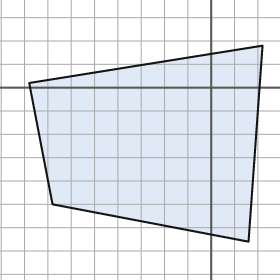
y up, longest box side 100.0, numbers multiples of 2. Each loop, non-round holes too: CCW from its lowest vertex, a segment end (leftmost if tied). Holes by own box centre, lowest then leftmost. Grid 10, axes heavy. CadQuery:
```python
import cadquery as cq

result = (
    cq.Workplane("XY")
    .moveTo(16.0, -66.0)
    .lineTo(22.0, 18.0)
    .lineTo(-78.0, 2.0)
    .lineTo(-68.0, -50.0)
    .close()
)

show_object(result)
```